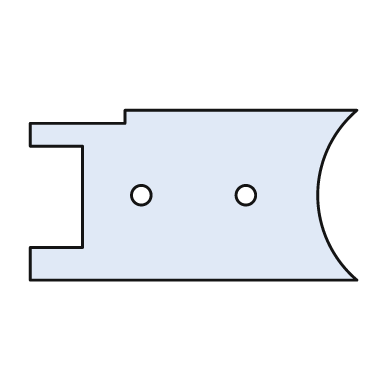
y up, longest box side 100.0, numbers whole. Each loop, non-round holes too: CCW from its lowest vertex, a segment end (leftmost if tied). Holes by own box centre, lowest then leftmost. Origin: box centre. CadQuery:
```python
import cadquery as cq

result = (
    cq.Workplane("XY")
    .moveTo(-50.0, -26.0)
    .lineTo(50.0, -26.0)
    .threePointArc((38.0, 0.0), (50.0, 26.0))
    .lineTo(-21.0, 26.0)
    .lineTo(-21.0, 22.0)
    .lineTo(-50.0, 22.0)
    .lineTo(-50.0, 15.0)
    .lineTo(-34.0, 15.0)
    .lineTo(-34.0, -16.0)
    .lineTo(-50.0, -16.0)
    .close()
    .moveTo(-16.0, 0.0)
    .circle(3.0)
    .moveTo(16.0, 0.0)
    .circle(3.0)
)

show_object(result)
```